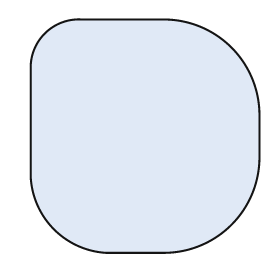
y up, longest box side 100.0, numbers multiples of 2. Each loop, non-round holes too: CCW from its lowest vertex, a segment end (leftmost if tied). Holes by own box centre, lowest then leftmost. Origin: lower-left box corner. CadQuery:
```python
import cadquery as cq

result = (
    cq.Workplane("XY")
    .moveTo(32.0, 0.0)
    .lineTo(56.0, 0.0)
    .threePointArc((86.0, 12.0), (98.0, 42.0))
    .lineTo(98.0, 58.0)
    .threePointArc((86.0, 88.0), (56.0, 100.0))
    .lineTo(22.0, 100.0)
    .threePointArc((6.0, 94.0), (0.0, 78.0))
    .lineTo(0.0, 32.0)
    .threePointArc((10.0, 10.0), (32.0, 0.0))
    .close()
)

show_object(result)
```